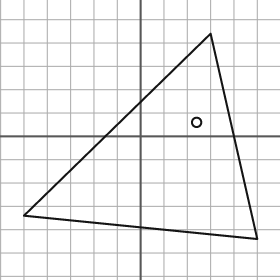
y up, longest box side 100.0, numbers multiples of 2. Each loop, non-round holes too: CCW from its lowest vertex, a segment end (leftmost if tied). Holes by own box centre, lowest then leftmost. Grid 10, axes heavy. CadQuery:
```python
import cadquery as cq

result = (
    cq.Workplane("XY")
    .moveTo(50.0, -44.0)
    .lineTo(30.0, 44.0)
    .lineTo(-50.0, -34.0)
    .close()
    .moveTo(24.0, 6.0)
    .circle(2.0)
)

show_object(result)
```